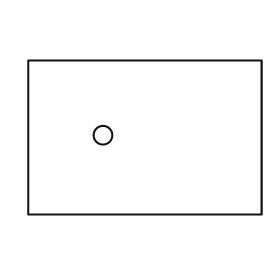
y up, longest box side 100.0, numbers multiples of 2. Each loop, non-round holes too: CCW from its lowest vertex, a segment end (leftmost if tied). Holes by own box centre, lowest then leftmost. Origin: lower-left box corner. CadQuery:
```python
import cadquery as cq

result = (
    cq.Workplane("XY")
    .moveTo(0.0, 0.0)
    .lineTo(100.0, 0.0)
    .lineTo(100.0, 66.0)
    .lineTo(0.0, 66.0)
    .close()
    .moveTo(32.0, 34.0)
    .circle(4.0)
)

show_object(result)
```